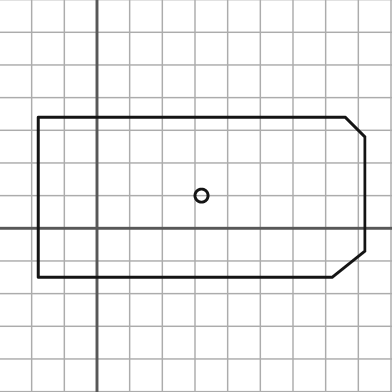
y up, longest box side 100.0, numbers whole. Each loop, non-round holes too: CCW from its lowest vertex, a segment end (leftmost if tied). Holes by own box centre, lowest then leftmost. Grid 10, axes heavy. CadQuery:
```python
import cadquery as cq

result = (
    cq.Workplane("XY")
    .moveTo(-18.0, -15.0)
    .lineTo(72.0, -15.0)
    .lineTo(82.0, -7.0)
    .lineTo(82.0, 28.0)
    .lineTo(76.0, 34.0)
    .lineTo(-18.0, 34.0)
    .close()
    .moveTo(32.0, 10.0)
    .circle(2.0)
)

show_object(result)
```